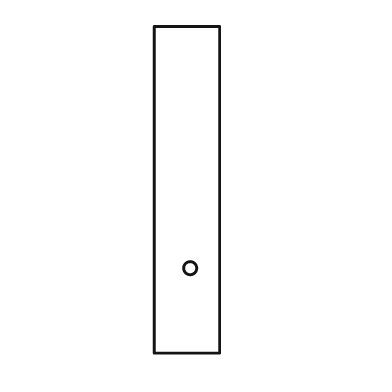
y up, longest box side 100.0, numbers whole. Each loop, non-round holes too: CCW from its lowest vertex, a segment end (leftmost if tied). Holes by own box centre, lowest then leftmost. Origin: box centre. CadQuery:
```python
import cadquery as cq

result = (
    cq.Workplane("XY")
    .moveTo(-10.0, -50.0)
    .lineTo(10.0, -50.0)
    .lineTo(10.0, 50.0)
    .lineTo(-10.0, 50.0)
    .close()
    .moveTo(1.0, -24.0)
    .circle(2.0)
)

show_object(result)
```